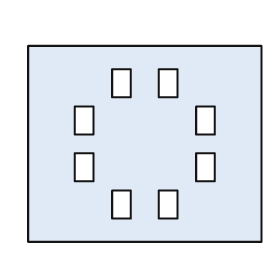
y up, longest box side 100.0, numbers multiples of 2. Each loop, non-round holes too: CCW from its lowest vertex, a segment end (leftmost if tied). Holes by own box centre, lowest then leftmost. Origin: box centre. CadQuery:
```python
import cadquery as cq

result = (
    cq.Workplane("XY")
    .moveTo(-50.0, -42.0)
    .lineTo(50.0, -42.0)
    .lineTo(50.0, 42.0)
    .lineTo(-50.0, 42.0)
    .close()
    .moveTo(-14.0, -32.0)
    .lineTo(-6.0, -32.0)
    .lineTo(-6.0, -20.0)
    .lineTo(-14.0, -20.0)
    .close()
    .moveTo(6.0, -32.0)
    .lineTo(14.0, -32.0)
    .lineTo(14.0, -20.0)
    .lineTo(6.0, -20.0)
    .close()
    .moveTo(-30.0, -16.0)
    .lineTo(-22.0, -16.0)
    .lineTo(-22.0, -4.0)
    .lineTo(-30.0, -4.0)
    .close()
    .moveTo(22.0, -16.0)
    .lineTo(30.0, -16.0)
    .lineTo(30.0, -4.0)
    .lineTo(22.0, -4.0)
    .close()
    .moveTo(-30.0, 4.0)
    .lineTo(-22.0, 4.0)
    .lineTo(-22.0, 16.0)
    .lineTo(-30.0, 16.0)
    .close()
    .moveTo(22.0, 4.0)
    .lineTo(30.0, 4.0)
    .lineTo(30.0, 16.0)
    .lineTo(22.0, 16.0)
    .close()
    .moveTo(-14.0, 20.0)
    .lineTo(-6.0, 20.0)
    .lineTo(-6.0, 32.0)
    .lineTo(-14.0, 32.0)
    .close()
    .moveTo(6.0, 20.0)
    .lineTo(14.0, 20.0)
    .lineTo(14.0, 32.0)
    .lineTo(6.0, 32.0)
    .close()
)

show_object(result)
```